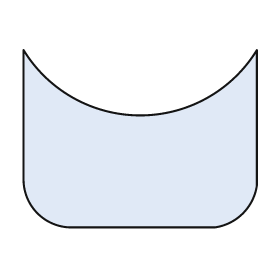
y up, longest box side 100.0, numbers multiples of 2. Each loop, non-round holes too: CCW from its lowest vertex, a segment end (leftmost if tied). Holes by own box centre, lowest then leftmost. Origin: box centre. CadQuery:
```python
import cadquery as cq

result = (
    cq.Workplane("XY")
    .moveTo(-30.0, -38.0)
    .lineTo(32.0, -38.0)
    .threePointArc((44.0, -32.0), (50.0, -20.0))
    .lineTo(50.0, 38.0)
    .threePointArc((0.0, 10.0), (-50.0, 38.0))
    .lineTo(-50.0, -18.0)
    .threePointArc((-44.0, -32.0), (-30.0, -38.0))
    .close()
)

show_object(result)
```